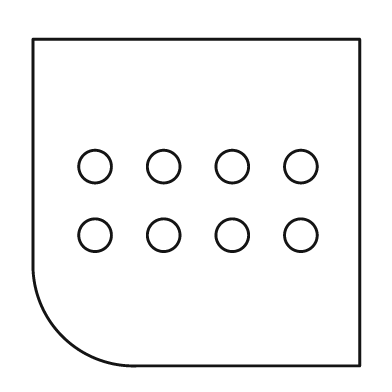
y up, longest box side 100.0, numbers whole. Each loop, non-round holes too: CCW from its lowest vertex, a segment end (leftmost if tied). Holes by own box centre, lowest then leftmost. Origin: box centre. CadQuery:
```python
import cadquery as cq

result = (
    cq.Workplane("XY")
    .moveTo(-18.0, -50.0)
    .lineTo(50.0, -50.0)
    .lineTo(50.0, 50.0)
    .lineTo(-50.0, 50.0)
    .lineTo(-50.0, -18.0)
    .threePointArc((-41.0, -41.0), (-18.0, -50.0))
    .close()
    .moveTo(-31.0, -10.0)
    .circle(5.0)
    .moveTo(-10.0, -10.0)
    .circle(5.0)
    .moveTo(11.0, -10.0)
    .circle(5.0)
    .moveTo(32.0, -10.0)
    .circle(5.0)
    .moveTo(-31.0, 11.0)
    .circle(5.0)
    .moveTo(-10.0, 11.0)
    .circle(5.0)
    .moveTo(11.0, 11.0)
    .circle(5.0)
    .moveTo(32.0, 11.0)
    .circle(5.0)
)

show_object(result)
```